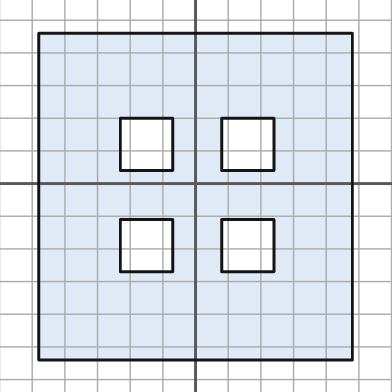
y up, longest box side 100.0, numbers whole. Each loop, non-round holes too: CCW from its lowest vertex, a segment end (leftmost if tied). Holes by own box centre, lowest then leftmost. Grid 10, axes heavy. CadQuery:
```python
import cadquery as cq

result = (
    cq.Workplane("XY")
    .moveTo(-48.0, -54.0)
    .lineTo(48.0, -54.0)
    .lineTo(48.0, 46.0)
    .lineTo(-48.0, 46.0)
    .close()
    .moveTo(-23.0, -27.0)
    .lineTo(-7.0, -27.0)
    .lineTo(-7.0, -11.0)
    .lineTo(-23.0, -11.0)
    .close()
    .moveTo(8.0, -27.0)
    .lineTo(24.0, -27.0)
    .lineTo(24.0, -11.0)
    .lineTo(8.0, -11.0)
    .close()
    .moveTo(-23.0, 4.0)
    .lineTo(-7.0, 4.0)
    .lineTo(-7.0, 20.0)
    .lineTo(-23.0, 20.0)
    .close()
    .moveTo(8.0, 4.0)
    .lineTo(24.0, 4.0)
    .lineTo(24.0, 20.0)
    .lineTo(8.0, 20.0)
    .close()
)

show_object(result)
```